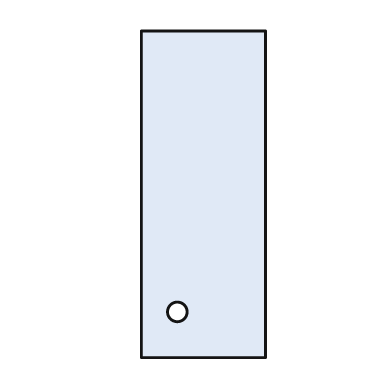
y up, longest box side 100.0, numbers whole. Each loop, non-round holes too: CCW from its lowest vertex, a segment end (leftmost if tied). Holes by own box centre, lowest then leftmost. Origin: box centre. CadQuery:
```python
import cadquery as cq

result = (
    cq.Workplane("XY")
    .moveTo(-19.0, -50.0)
    .lineTo(19.0, -50.0)
    .lineTo(19.0, 50.0)
    .lineTo(-19.0, 50.0)
    .close()
    .moveTo(-8.0, -36.0)
    .circle(3.0)
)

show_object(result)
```